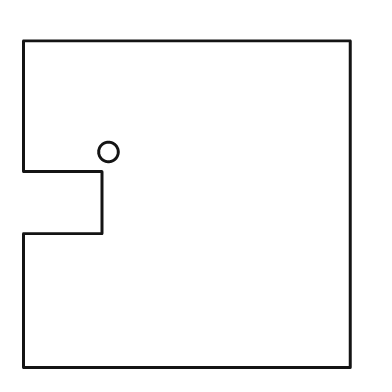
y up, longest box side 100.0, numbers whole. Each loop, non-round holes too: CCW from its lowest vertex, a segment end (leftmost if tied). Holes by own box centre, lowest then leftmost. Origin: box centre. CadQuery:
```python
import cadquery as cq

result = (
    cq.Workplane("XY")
    .moveTo(-50.0, -50.0)
    .lineTo(50.0, -50.0)
    .lineTo(50.0, 50.0)
    .lineTo(-50.0, 50.0)
    .lineTo(-50.0, 10.0)
    .lineTo(-26.0, 10.0)
    .lineTo(-26.0, -9.0)
    .lineTo(-50.0, -9.0)
    .close()
    .moveTo(-24.0, 16.0)
    .circle(3.0)
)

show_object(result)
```